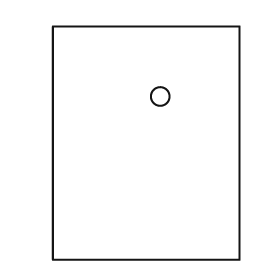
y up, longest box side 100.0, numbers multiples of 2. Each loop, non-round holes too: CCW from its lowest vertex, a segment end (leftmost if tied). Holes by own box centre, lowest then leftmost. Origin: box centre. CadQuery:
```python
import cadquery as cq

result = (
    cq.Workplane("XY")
    .moveTo(-40.0, -50.0)
    .lineTo(40.0, -50.0)
    .lineTo(40.0, 50.0)
    .lineTo(-40.0, 50.0)
    .close()
    .moveTo(6.0, 20.0)
    .circle(4.0)
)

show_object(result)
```